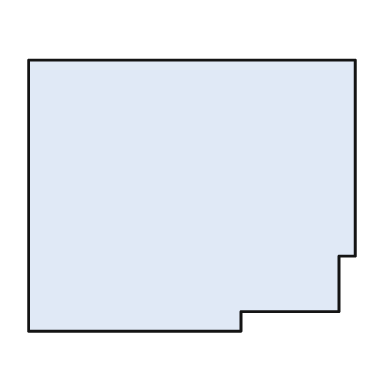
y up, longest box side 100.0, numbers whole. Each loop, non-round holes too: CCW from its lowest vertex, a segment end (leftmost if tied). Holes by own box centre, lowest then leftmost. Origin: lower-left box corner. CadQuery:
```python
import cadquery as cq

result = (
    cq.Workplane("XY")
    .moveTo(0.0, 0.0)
    .lineTo(65.0, 0.0)
    .lineTo(65.0, 6.0)
    .lineTo(95.0, 6.0)
    .lineTo(95.0, 23.0)
    .lineTo(100.0, 23.0)
    .lineTo(100.0, 83.0)
    .lineTo(0.0, 83.0)
    .close()
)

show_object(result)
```